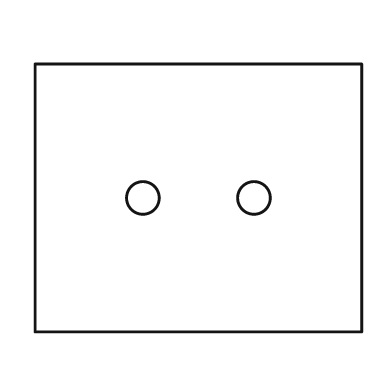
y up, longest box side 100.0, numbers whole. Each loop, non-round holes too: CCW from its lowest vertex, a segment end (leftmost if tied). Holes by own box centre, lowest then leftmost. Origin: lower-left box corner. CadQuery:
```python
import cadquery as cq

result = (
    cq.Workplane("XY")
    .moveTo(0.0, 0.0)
    .lineTo(100.0, 0.0)
    .lineTo(100.0, 82.0)
    .lineTo(0.0, 82.0)
    .close()
    .moveTo(33.0, 41.0)
    .circle(5.0)
    .moveTo(67.0, 41.0)
    .circle(5.0)
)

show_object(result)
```